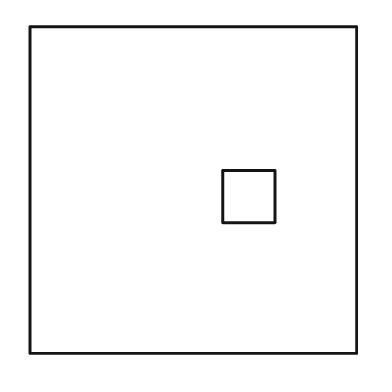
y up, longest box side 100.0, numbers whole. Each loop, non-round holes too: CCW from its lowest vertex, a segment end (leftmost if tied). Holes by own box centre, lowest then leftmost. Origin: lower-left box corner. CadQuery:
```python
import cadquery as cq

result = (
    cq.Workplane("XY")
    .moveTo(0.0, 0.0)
    .lineTo(100.0, 0.0)
    .lineTo(100.0, 100.0)
    .lineTo(0.0, 100.0)
    .close()
    .moveTo(59.0, 40.0)
    .lineTo(75.0, 40.0)
    .lineTo(75.0, 56.0)
    .lineTo(59.0, 56.0)
    .close()
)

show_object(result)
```